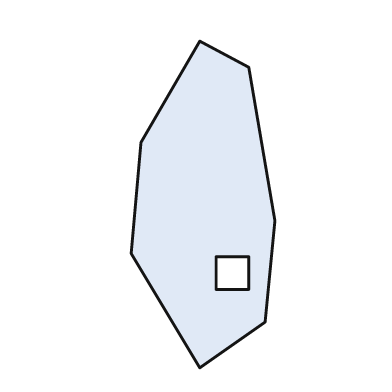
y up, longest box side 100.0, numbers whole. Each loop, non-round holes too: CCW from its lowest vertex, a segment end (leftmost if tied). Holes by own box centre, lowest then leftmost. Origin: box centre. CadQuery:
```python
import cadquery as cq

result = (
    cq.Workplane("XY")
    .moveTo(-1.0, -50.0)
    .lineTo(19.0, -36.0)
    .lineTo(22.0, -5.0)
    .lineTo(14.0, 42.0)
    .lineTo(-1.0, 50.0)
    .lineTo(-19.0, 19.0)
    .lineTo(-22.0, -15.0)
    .close()
    .moveTo(4.0, -26.0)
    .lineTo(14.0, -26.0)
    .lineTo(14.0, -16.0)
    .lineTo(4.0, -16.0)
    .close()
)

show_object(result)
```